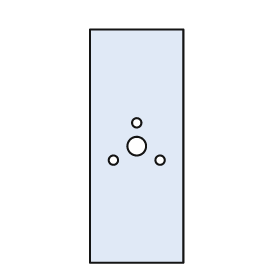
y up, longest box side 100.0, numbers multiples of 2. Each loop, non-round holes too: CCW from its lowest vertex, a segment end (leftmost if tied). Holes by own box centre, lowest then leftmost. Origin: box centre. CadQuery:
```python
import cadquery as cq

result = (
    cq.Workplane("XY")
    .moveTo(-20.0, -50.0)
    .lineTo(20.0, -50.0)
    .lineTo(20.0, 50.0)
    .lineTo(-20.0, 50.0)
    .close()
    .moveTo(-10.0, -6.0)
    .circle(2.0)
    .moveTo(10.0, -6.0)
    .circle(2.0)
    .moveTo(0.0, 0.0)
    .circle(4.0)
    .moveTo(0.0, 10.0)
    .circle(2.0)
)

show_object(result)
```